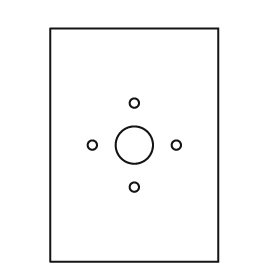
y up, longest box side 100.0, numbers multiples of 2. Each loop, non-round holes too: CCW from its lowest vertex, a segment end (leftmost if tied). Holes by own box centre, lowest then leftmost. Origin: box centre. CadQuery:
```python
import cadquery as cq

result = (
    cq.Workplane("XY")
    .moveTo(-36.0, -50.0)
    .lineTo(36.0, -50.0)
    .lineTo(36.0, 50.0)
    .lineTo(-36.0, 50.0)
    .close()
    .moveTo(0.0, -18.0)
    .circle(2.0)
    .moveTo(-18.0, 0.0)
    .circle(2.0)
    .moveTo(0.0, 0.0)
    .circle(8.0)
    .moveTo(18.0, 0.0)
    .circle(2.0)
    .moveTo(0.0, 18.0)
    .circle(2.0)
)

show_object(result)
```